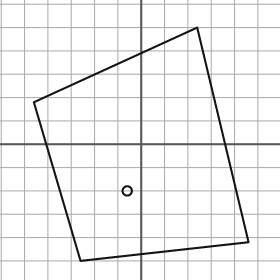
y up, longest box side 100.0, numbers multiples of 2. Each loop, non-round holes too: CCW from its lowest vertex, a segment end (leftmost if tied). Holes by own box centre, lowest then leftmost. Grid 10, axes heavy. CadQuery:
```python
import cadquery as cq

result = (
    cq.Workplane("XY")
    .moveTo(-26.0, -50.0)
    .lineTo(46.0, -42.0)
    .lineTo(24.0, 50.0)
    .lineTo(-46.0, 18.0)
    .close()
    .moveTo(-6.0, -20.0)
    .circle(2.0)
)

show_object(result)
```